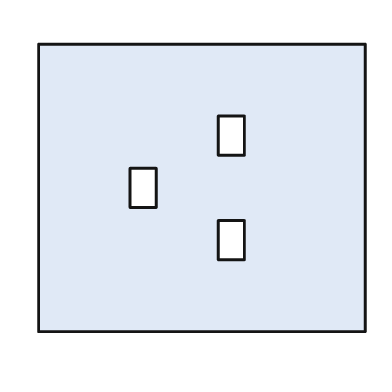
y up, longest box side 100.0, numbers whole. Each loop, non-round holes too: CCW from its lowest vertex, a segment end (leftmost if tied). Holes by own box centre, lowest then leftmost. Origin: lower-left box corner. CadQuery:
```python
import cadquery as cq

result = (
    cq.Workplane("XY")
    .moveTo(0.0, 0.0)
    .lineTo(100.0, 0.0)
    .lineTo(100.0, 88.0)
    .lineTo(0.0, 88.0)
    .close()
    .moveTo(55.0, 22.0)
    .lineTo(63.0, 22.0)
    .lineTo(63.0, 34.0)
    .lineTo(55.0, 34.0)
    .close()
    .moveTo(28.0, 38.0)
    .lineTo(36.0, 38.0)
    .lineTo(36.0, 50.0)
    .lineTo(28.0, 50.0)
    .close()
    .moveTo(55.0, 54.0)
    .lineTo(63.0, 54.0)
    .lineTo(63.0, 66.0)
    .lineTo(55.0, 66.0)
    .close()
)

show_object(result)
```